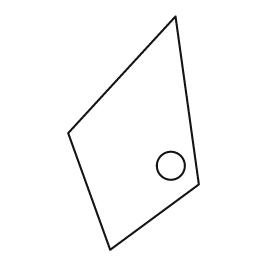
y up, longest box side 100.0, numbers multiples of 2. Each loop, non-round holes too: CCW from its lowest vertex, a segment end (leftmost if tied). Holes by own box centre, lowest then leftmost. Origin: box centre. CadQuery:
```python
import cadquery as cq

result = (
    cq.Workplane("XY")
    .moveTo(-10.0, -50.0)
    .lineTo(28.0, -22.0)
    .lineTo(18.0, 50.0)
    .lineTo(-28.0, 0.0)
    .close()
    .moveTo(16.0, -14.0)
    .circle(6.0)
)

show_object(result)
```